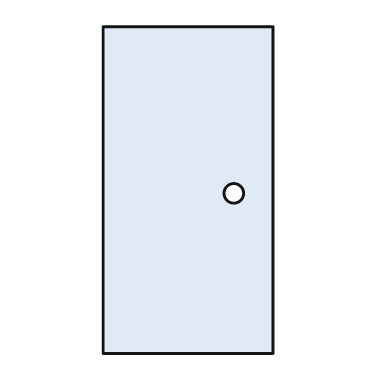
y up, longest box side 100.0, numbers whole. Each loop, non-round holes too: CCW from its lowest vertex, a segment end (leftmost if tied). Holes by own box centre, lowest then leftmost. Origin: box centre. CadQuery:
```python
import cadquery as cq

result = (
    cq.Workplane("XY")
    .moveTo(-26.0, -50.0)
    .lineTo(26.0, -50.0)
    .lineTo(26.0, 50.0)
    .lineTo(-26.0, 50.0)
    .close()
    .moveTo(14.0, -1.0)
    .circle(3.0)
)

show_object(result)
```